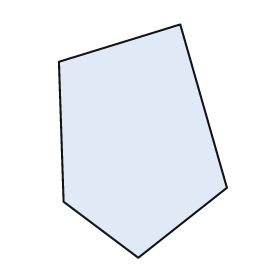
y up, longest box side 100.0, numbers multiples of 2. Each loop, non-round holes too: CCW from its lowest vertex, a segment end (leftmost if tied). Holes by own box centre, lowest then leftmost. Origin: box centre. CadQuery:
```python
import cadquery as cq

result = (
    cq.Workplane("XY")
    .moveTo(-2.0, -50.0)
    .lineTo(36.0, -20.0)
    .lineTo(16.0, 50.0)
    .lineTo(-36.0, 34.0)
    .lineTo(-34.0, -26.0)
    .close()
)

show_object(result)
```